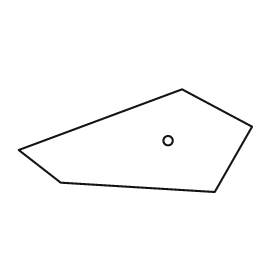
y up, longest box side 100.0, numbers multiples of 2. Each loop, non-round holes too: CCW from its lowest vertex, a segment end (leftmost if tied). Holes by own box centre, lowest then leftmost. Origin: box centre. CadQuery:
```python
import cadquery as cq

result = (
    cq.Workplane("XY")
    .moveTo(34.0, -22.0)
    .lineTo(50.0, 6.0)
    .lineTo(20.0, 22.0)
    .lineTo(-50.0, -4.0)
    .lineTo(-32.0, -18.0)
    .close()
    .moveTo(14.0, 0.0)
    .circle(2.0)
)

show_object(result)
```